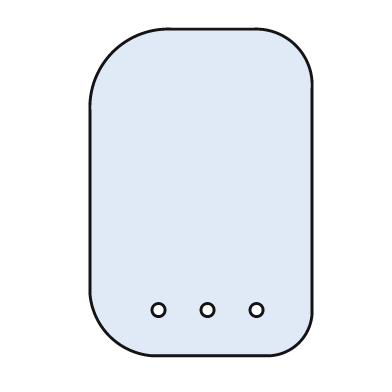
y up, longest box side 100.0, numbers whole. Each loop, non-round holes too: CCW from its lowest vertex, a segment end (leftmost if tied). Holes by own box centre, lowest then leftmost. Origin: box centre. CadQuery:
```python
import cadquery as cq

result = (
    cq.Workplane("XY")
    .moveTo(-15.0, -50.0)
    .lineTo(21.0, -50.0)
    .threePointArc((30.0, -46.0), (34.0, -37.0))
    .lineTo(34.0, 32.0)
    .threePointArc((29.0, 45.0), (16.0, 50.0))
    .lineTo(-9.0, 50.0)
    .threePointArc((-27.0, 43.0), (-34.0, 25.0))
    .lineTo(-34.0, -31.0)
    .threePointArc((-28.0, -44.0), (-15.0, -50.0))
    .close()
    .moveTo(-13.0, -36.0)
    .circle(2.0)
    .moveTo(2.0, -36.0)
    .circle(2.0)
    .moveTo(17.0, -36.0)
    .circle(2.0)
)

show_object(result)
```